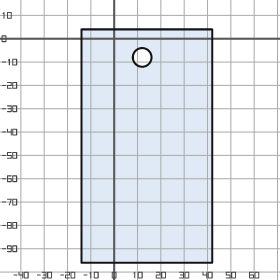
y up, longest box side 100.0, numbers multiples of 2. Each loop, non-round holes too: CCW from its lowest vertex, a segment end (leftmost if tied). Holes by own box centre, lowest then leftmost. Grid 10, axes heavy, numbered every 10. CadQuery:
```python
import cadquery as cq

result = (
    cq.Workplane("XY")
    .moveTo(-14.0, -96.0)
    .lineTo(42.0, -96.0)
    .lineTo(42.0, 4.0)
    .lineTo(-14.0, 4.0)
    .close()
    .moveTo(12.0, -8.0)
    .circle(4.0)
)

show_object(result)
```